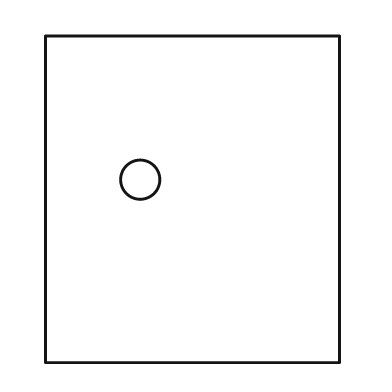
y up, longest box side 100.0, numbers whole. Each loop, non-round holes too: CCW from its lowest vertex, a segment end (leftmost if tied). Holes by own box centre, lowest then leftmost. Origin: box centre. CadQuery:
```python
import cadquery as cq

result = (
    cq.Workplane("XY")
    .moveTo(-45.0, -50.0)
    .lineTo(45.0, -50.0)
    .lineTo(45.0, 50.0)
    .lineTo(-45.0, 50.0)
    .close()
    .moveTo(-16.0, 6.0)
    .circle(6.0)
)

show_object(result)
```